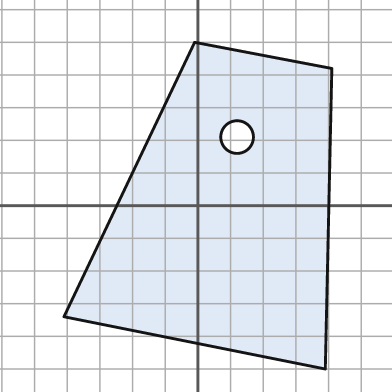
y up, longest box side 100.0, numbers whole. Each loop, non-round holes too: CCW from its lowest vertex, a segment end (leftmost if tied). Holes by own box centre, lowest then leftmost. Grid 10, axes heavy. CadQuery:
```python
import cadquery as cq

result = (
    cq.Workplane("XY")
    .moveTo(39.0, -50.0)
    .lineTo(41.0, 42.0)
    .lineTo(-1.0, 50.0)
    .lineTo(-41.0, -34.0)
    .close()
    .moveTo(12.0, 21.0)
    .circle(5.0)
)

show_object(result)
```